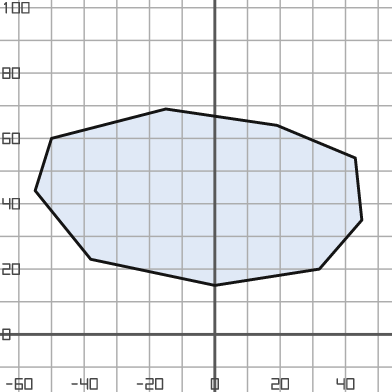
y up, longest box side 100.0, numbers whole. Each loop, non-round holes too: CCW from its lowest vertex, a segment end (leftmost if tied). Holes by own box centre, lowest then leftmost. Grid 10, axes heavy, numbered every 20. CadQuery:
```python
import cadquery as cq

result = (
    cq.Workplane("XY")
    .moveTo(0.0, 15.0)
    .lineTo(32.0, 20.0)
    .lineTo(45.0, 35.0)
    .lineTo(43.0, 54.0)
    .lineTo(19.0, 64.0)
    .lineTo(-15.0, 69.0)
    .lineTo(-50.0, 60.0)
    .lineTo(-55.0, 44.0)
    .lineTo(-38.0, 23.0)
    .close()
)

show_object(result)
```